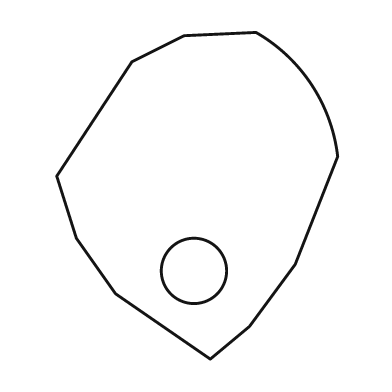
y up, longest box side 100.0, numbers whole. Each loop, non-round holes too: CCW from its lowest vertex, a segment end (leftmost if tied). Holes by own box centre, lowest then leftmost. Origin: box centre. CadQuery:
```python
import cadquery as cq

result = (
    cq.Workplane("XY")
    .moveTo(4.0, -50.0)
    .lineTo(16.0, -40.0)
    .lineTo(30.0, -21.0)
    .lineTo(43.0, 12.0)
    .threePointArc((35.0, 34.0), (18.0, 50.0))
    .lineTo(-4.0, 49.0)
    .lineTo(-20.0, 41.0)
    .lineTo(-43.0, 6.0)
    .lineTo(-37.0, -13.0)
    .lineTo(-25.0, -30.0)
    .close()
    .moveTo(-1.0, -23.0)
    .circle(10.0)
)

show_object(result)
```